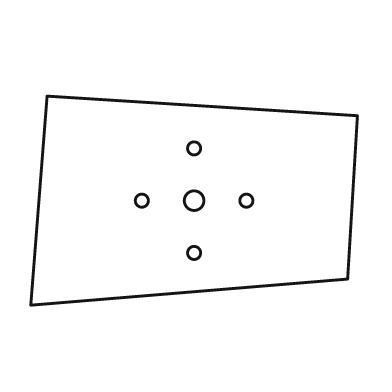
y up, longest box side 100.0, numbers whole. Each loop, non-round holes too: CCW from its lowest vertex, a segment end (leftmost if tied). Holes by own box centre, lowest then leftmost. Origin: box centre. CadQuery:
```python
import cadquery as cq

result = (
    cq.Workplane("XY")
    .moveTo(-50.0, -32.0)
    .lineTo(47.0, -24.0)
    .lineTo(50.0, 26.0)
    .lineTo(-45.0, 32.0)
    .close()
    .moveTo(0.0, -16.0)
    .circle(2.0)
    .moveTo(-16.0, 0.0)
    .circle(2.0)
    .moveTo(0.0, 0.0)
    .circle(3.0)
    .moveTo(16.0, 0.0)
    .circle(2.0)
    .moveTo(0.0, 16.0)
    .circle(2.0)
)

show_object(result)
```